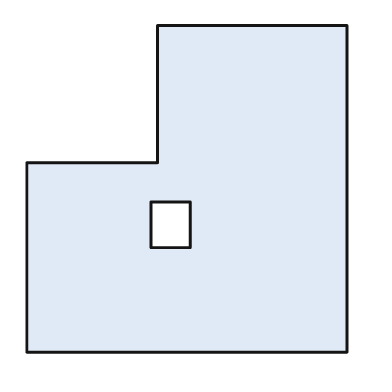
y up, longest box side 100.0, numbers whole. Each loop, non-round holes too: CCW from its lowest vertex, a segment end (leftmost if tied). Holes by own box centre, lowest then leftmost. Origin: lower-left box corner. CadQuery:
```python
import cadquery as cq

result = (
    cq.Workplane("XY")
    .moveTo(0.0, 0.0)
    .lineTo(98.0, 0.0)
    .lineTo(98.0, 100.0)
    .lineTo(40.0, 100.0)
    .lineTo(40.0, 58.0)
    .lineTo(0.0, 58.0)
    .close()
    .moveTo(38.0, 32.0)
    .lineTo(50.0, 32.0)
    .lineTo(50.0, 46.0)
    .lineTo(38.0, 46.0)
    .close()
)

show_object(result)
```